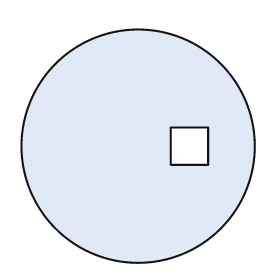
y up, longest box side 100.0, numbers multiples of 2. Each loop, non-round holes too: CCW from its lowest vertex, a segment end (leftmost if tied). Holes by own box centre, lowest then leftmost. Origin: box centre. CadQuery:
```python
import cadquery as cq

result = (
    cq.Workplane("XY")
    .moveTo(0.0, 0.0)
    .circle(50.0)
    .moveTo(14.0, -8.0)
    .lineTo(30.0, -8.0)
    .lineTo(30.0, 8.0)
    .lineTo(14.0, 8.0)
    .close()
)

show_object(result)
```